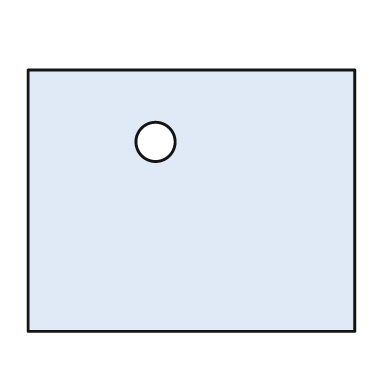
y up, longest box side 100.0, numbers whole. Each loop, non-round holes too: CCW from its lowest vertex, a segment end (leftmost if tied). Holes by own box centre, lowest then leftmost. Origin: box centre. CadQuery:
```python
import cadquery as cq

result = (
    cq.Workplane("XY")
    .moveTo(-50.0, -40.0)
    .lineTo(50.0, -40.0)
    .lineTo(50.0, 40.0)
    .lineTo(-50.0, 40.0)
    .close()
    .moveTo(-11.0, 18.0)
    .circle(6.0)
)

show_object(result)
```